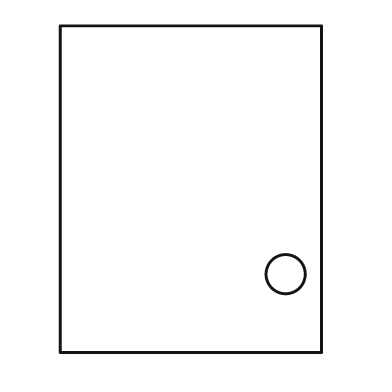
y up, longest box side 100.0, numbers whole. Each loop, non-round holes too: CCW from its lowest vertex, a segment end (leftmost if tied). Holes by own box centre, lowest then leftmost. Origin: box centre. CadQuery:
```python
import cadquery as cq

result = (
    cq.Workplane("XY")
    .moveTo(-40.0, -50.0)
    .lineTo(40.0, -50.0)
    .lineTo(40.0, 50.0)
    .lineTo(-40.0, 50.0)
    .close()
    .moveTo(29.0, -26.0)
    .circle(6.0)
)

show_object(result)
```